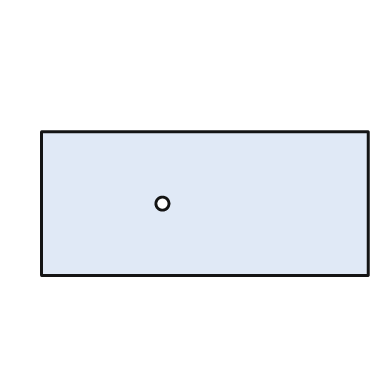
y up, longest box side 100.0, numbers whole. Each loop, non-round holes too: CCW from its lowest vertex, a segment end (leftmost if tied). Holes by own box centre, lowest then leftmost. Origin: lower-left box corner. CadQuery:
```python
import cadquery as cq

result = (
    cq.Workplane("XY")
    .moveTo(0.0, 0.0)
    .lineTo(100.0, 0.0)
    .lineTo(100.0, 44.0)
    .lineTo(0.0, 44.0)
    .close()
    .moveTo(37.0, 22.0)
    .circle(2.0)
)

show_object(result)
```